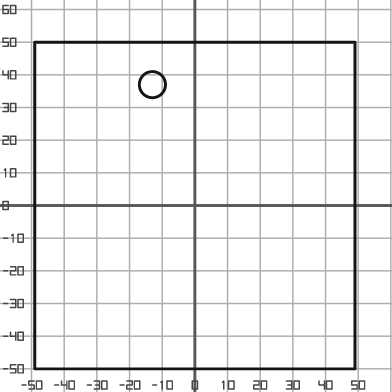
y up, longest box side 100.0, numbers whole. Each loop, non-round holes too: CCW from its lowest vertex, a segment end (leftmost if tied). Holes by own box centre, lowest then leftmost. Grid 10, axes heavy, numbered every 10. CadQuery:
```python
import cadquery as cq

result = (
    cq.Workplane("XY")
    .moveTo(-49.0, -50.0)
    .lineTo(49.0, -50.0)
    .lineTo(49.0, 50.0)
    .lineTo(-49.0, 50.0)
    .close()
    .moveTo(-13.0, 37.0)
    .circle(4.0)
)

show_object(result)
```